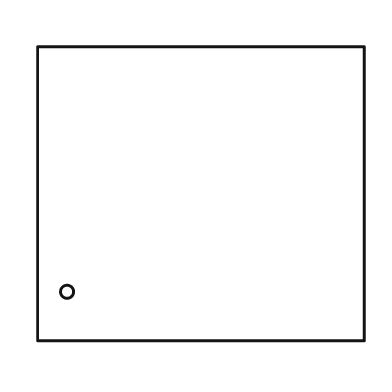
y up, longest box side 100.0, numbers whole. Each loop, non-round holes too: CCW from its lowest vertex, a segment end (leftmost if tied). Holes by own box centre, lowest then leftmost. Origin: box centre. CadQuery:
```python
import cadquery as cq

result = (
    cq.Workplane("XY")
    .moveTo(-50.0, -45.0)
    .lineTo(50.0, -45.0)
    .lineTo(50.0, 45.0)
    .lineTo(-50.0, 45.0)
    .close()
    .moveTo(-41.0, -30.0)
    .circle(2.0)
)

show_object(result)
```